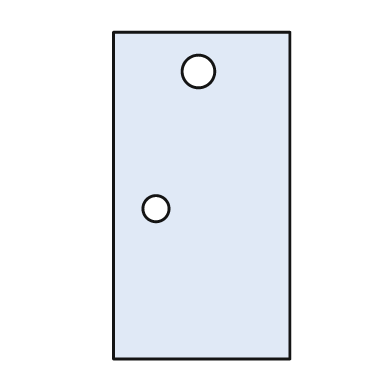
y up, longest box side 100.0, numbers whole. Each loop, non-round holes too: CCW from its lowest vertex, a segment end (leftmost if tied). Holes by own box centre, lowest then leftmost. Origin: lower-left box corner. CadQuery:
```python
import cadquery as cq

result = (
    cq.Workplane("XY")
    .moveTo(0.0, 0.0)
    .lineTo(54.0, 0.0)
    .lineTo(54.0, 100.0)
    .lineTo(0.0, 100.0)
    .close()
    .moveTo(13.0, 46.0)
    .circle(4.0)
    .moveTo(26.0, 88.0)
    .circle(5.0)
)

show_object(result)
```